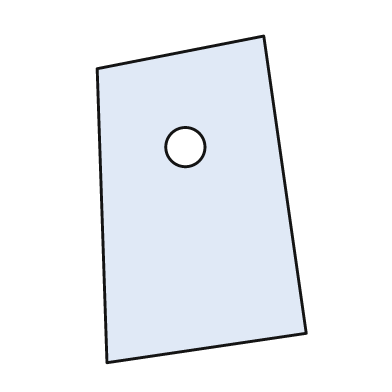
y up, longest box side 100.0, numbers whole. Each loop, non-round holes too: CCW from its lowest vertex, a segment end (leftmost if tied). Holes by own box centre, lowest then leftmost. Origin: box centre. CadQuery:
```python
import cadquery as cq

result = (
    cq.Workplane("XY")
    .moveTo(-29.0, -50.0)
    .lineTo(32.0, -41.0)
    .lineTo(19.0, 50.0)
    .lineTo(-32.0, 40.0)
    .close()
    .moveTo(-5.0, 16.0)
    .circle(6.0)
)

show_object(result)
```